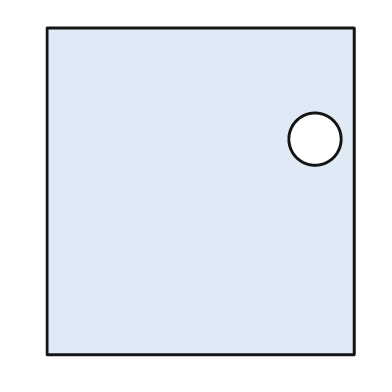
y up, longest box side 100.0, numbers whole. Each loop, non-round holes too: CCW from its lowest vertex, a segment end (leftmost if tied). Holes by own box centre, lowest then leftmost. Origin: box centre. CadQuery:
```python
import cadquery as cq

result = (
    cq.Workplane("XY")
    .moveTo(-47.0, -50.0)
    .lineTo(47.0, -50.0)
    .lineTo(47.0, 50.0)
    .lineTo(-47.0, 50.0)
    .close()
    .moveTo(35.0, 16.0)
    .circle(8.0)
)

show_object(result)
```